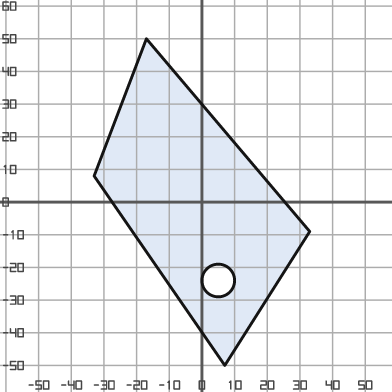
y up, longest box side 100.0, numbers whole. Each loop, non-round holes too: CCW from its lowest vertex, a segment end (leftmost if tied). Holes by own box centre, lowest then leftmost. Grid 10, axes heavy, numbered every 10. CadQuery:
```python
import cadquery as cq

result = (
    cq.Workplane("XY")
    .moveTo(7.0, -50.0)
    .lineTo(33.0, -9.0)
    .lineTo(-17.0, 50.0)
    .lineTo(-33.0, 8.0)
    .close()
    .moveTo(5.0, -24.0)
    .circle(5.0)
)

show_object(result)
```